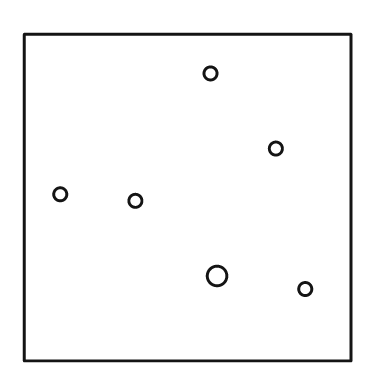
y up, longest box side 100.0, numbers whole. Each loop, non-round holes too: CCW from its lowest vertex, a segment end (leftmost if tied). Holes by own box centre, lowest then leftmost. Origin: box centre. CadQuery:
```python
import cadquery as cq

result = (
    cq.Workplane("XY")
    .moveTo(-50.0, -50.0)
    .lineTo(50.0, -50.0)
    .lineTo(50.0, 50.0)
    .lineTo(-50.0, 50.0)
    .close()
    .moveTo(36.0, -28.0)
    .circle(2.0)
    .moveTo(9.0, -24.0)
    .circle(3.0)
    .moveTo(-16.0, -1.0)
    .circle(2.0)
    .moveTo(-39.0, 1.0)
    .circle(2.0)
    .moveTo(27.0, 15.0)
    .circle(2.0)
    .moveTo(7.0, 38.0)
    .circle(2.0)
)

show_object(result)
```